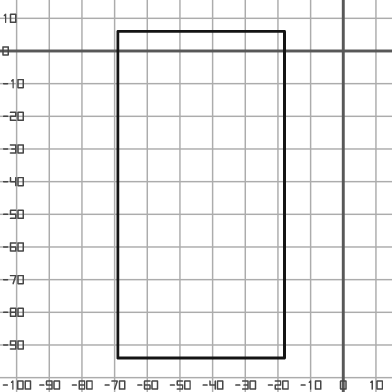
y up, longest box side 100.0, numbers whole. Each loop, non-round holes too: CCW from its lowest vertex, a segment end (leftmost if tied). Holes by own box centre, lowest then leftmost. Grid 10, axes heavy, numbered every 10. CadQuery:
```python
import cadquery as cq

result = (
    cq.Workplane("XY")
    .moveTo(-69.0, -94.0)
    .lineTo(-18.0, -94.0)
    .lineTo(-18.0, 6.0)
    .lineTo(-69.0, 6.0)
    .close()
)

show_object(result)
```